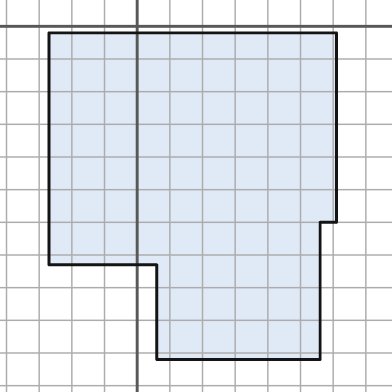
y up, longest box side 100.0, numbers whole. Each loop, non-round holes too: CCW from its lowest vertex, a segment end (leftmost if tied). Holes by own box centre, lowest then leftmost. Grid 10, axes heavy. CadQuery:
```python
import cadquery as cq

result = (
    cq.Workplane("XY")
    .moveTo(6.0, -102.0)
    .lineTo(56.0, -102.0)
    .lineTo(56.0, -60.0)
    .lineTo(61.0, -60.0)
    .lineTo(61.0, -2.0)
    .lineTo(-27.0, -2.0)
    .lineTo(-27.0, -73.0)
    .lineTo(6.0, -73.0)
    .close()
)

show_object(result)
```